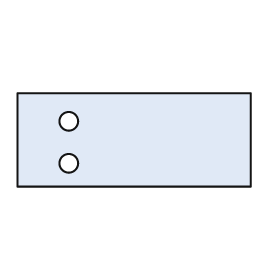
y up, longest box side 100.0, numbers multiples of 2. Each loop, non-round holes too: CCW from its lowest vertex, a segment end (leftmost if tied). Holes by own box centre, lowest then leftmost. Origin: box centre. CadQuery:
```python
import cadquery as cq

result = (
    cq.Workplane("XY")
    .moveTo(-50.0, -20.0)
    .lineTo(50.0, -20.0)
    .lineTo(50.0, 20.0)
    .lineTo(-50.0, 20.0)
    .close()
    .moveTo(-28.0, -10.0)
    .circle(4.0)
    .moveTo(-28.0, 8.0)
    .circle(4.0)
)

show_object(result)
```